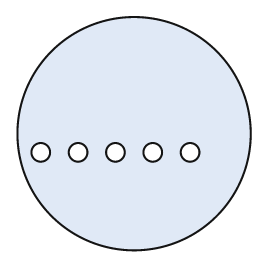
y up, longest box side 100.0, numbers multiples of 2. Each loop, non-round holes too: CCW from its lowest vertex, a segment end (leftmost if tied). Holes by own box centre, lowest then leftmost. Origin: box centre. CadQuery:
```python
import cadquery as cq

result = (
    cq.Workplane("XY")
    .moveTo(0.0, 0.0)
    .circle(50.0)
    .moveTo(-40.0, -8.0)
    .circle(4.0)
    .moveTo(-24.0, -8.0)
    .circle(4.0)
    .moveTo(-8.0, -8.0)
    .circle(4.0)
    .moveTo(8.0, -8.0)
    .circle(4.0)
    .moveTo(24.0, -8.0)
    .circle(4.0)
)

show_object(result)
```